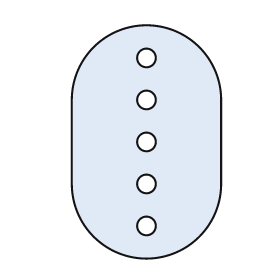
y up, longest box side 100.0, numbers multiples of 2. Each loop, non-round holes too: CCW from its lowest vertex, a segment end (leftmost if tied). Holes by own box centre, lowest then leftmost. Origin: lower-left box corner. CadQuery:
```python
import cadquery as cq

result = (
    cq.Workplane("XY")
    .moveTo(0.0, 32.0)
    .threePointArc((32.0, 0.0), (64.0, 32.0))
    .lineTo(64.0, 68.0)
    .threePointArc((32.0, 100.0), (0.0, 68.0))
    .close()
    .moveTo(32.0, 14.0)
    .circle(4.0)
    .moveTo(32.0, 32.0)
    .circle(4.0)
    .moveTo(32.0, 50.0)
    .circle(4.0)
    .moveTo(32.0, 68.0)
    .circle(4.0)
    .moveTo(32.0, 86.0)
    .circle(4.0)
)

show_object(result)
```